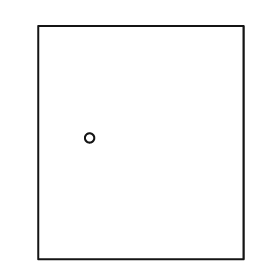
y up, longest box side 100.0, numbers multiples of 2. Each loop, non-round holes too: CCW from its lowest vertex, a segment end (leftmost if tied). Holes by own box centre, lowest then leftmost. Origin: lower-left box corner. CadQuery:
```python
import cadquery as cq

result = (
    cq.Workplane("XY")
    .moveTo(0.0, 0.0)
    .lineTo(88.0, 0.0)
    .lineTo(88.0, 100.0)
    .lineTo(0.0, 100.0)
    .close()
    .moveTo(22.0, 52.0)
    .circle(2.0)
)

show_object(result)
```